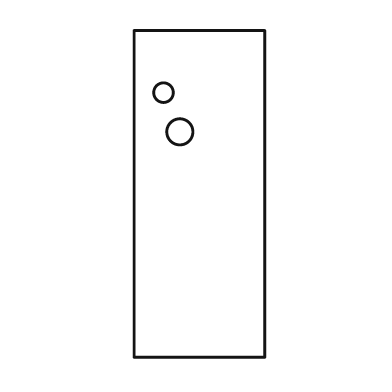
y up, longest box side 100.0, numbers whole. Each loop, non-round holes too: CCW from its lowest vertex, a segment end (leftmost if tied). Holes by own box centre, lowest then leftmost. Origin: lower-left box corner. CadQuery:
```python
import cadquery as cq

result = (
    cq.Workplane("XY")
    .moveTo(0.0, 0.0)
    .lineTo(40.0, 0.0)
    .lineTo(40.0, 100.0)
    .lineTo(0.0, 100.0)
    .close()
    .moveTo(14.0, 69.0)
    .circle(4.0)
    .moveTo(9.0, 81.0)
    .circle(3.0)
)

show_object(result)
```